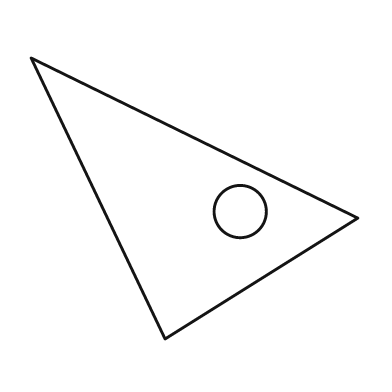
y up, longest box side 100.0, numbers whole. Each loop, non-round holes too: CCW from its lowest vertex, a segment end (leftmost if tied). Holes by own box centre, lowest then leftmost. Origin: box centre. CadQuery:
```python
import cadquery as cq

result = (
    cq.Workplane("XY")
    .moveTo(-9.0, -43.0)
    .lineTo(50.0, -6.0)
    .lineTo(-50.0, 43.0)
    .close()
    .moveTo(14.0, -4.0)
    .circle(8.0)
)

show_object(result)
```